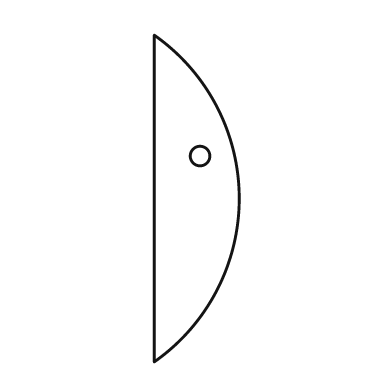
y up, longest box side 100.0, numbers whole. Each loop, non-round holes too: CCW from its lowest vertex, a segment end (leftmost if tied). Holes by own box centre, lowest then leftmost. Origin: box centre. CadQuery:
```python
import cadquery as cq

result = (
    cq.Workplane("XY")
    .moveTo(-13.0, -50.0)
    .threePointArc((13.0, 0.0), (-13.0, 50.0))
    .close()
    .moveTo(1.0, 13.0)
    .circle(3.0)
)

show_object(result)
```